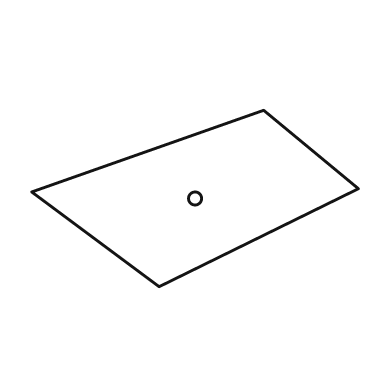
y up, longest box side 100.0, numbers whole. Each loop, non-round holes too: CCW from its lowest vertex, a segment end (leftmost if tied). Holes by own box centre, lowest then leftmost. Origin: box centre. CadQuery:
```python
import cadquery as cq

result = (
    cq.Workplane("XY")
    .moveTo(-11.0, -27.0)
    .lineTo(50.0, 3.0)
    .lineTo(21.0, 27.0)
    .lineTo(-50.0, 2.0)
    .close()
    .moveTo(0.0, 0.0)
    .circle(2.0)
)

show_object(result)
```